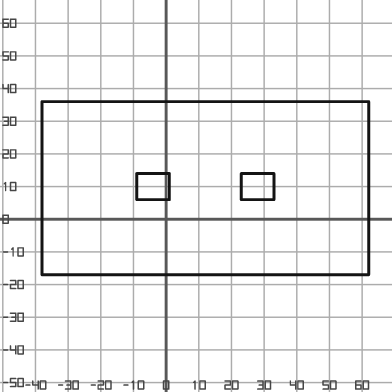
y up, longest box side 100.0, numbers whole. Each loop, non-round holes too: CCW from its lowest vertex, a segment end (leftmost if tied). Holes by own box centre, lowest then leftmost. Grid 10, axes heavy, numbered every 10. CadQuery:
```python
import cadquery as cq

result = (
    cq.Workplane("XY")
    .moveTo(-38.0, -17.0)
    .lineTo(62.0, -17.0)
    .lineTo(62.0, 36.0)
    .lineTo(-38.0, 36.0)
    .close()
    .moveTo(-9.0, 6.0)
    .lineTo(1.0, 6.0)
    .lineTo(1.0, 14.0)
    .lineTo(-9.0, 14.0)
    .close()
    .moveTo(23.0, 6.0)
    .lineTo(33.0, 6.0)
    .lineTo(33.0, 14.0)
    .lineTo(23.0, 14.0)
    .close()
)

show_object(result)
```